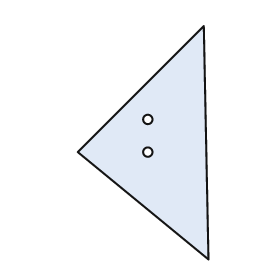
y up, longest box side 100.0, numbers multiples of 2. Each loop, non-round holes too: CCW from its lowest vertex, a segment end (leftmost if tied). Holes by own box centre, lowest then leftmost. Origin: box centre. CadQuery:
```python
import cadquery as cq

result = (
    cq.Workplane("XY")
    .moveTo(28.0, -50.0)
    .lineTo(26.0, 50.0)
    .lineTo(-28.0, -4.0)
    .close()
    .moveTo(2.0, -4.0)
    .circle(2.0)
    .moveTo(2.0, 10.0)
    .circle(2.0)
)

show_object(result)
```